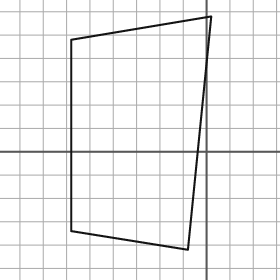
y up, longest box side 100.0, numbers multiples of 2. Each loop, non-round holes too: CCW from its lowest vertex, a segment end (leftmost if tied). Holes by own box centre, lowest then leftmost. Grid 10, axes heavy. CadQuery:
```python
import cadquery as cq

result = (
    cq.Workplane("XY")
    .moveTo(-8.0, -42.0)
    .lineTo(2.0, 58.0)
    .lineTo(-58.0, 48.0)
    .lineTo(-58.0, -34.0)
    .close()
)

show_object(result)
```